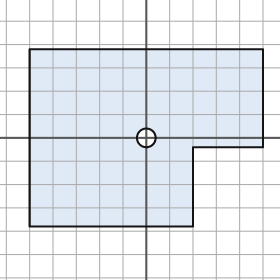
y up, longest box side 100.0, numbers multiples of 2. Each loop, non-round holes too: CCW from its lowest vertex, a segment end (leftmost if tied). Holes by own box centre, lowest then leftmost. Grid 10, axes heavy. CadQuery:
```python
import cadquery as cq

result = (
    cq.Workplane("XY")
    .moveTo(-50.0, -38.0)
    .lineTo(20.0, -38.0)
    .lineTo(20.0, -4.0)
    .lineTo(50.0, -4.0)
    .lineTo(50.0, 38.0)
    .lineTo(-50.0, 38.0)
    .close()
    .moveTo(0.0, 0.0)
    .circle(4.0)
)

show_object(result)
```